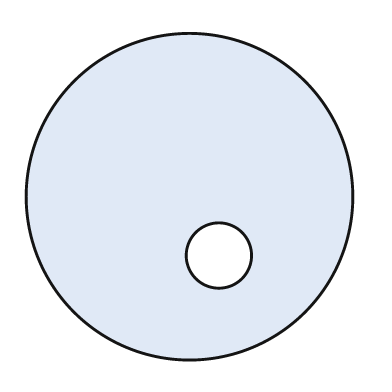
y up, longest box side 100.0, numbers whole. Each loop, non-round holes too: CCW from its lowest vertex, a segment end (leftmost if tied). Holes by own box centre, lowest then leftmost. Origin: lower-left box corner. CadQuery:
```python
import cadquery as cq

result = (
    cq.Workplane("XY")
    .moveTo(50.0, 50.0)
    .circle(50.0)
    .moveTo(59.0, 32.0)
    .circle(10.0)
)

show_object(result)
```